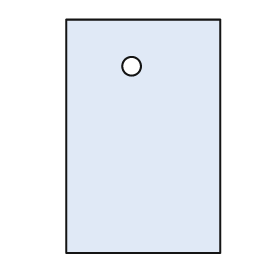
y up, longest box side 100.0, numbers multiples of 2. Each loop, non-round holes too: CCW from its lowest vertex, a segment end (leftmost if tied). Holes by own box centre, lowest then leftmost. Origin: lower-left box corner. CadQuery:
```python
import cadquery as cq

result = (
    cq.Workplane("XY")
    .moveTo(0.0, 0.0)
    .lineTo(66.0, 0.0)
    .lineTo(66.0, 100.0)
    .lineTo(0.0, 100.0)
    .close()
    .moveTo(28.0, 80.0)
    .circle(4.0)
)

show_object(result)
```